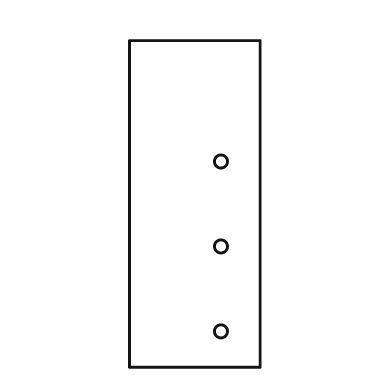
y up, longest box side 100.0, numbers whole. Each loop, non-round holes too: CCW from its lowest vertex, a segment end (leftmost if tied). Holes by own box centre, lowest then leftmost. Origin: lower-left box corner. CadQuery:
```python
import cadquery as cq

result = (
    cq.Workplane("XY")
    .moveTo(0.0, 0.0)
    .lineTo(40.0, 0.0)
    .lineTo(40.0, 100.0)
    .lineTo(0.0, 100.0)
    .close()
    .moveTo(28.0, 11.0)
    .circle(2.0)
    .moveTo(28.0, 37.0)
    .circle(2.0)
    .moveTo(28.0, 63.0)
    .circle(2.0)
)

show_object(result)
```